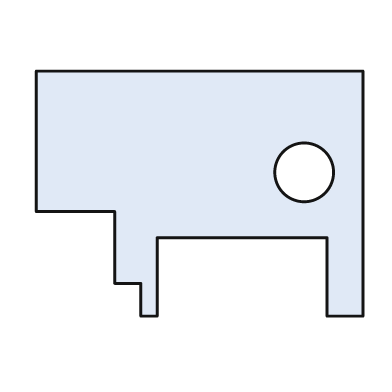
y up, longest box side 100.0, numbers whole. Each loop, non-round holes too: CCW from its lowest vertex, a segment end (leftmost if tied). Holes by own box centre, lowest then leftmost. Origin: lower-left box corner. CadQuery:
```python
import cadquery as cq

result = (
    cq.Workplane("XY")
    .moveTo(32.0, 0.0)
    .lineTo(37.0, 0.0)
    .lineTo(37.0, 24.0)
    .lineTo(89.0, 24.0)
    .lineTo(89.0, 0.0)
    .lineTo(100.0, 0.0)
    .lineTo(100.0, 75.0)
    .lineTo(0.0, 75.0)
    .lineTo(0.0, 32.0)
    .lineTo(24.0, 32.0)
    .lineTo(24.0, 10.0)
    .lineTo(32.0, 10.0)
    .close()
    .moveTo(82.0, 44.0)
    .circle(9.0)
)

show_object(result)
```